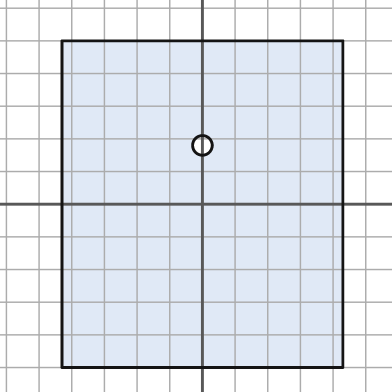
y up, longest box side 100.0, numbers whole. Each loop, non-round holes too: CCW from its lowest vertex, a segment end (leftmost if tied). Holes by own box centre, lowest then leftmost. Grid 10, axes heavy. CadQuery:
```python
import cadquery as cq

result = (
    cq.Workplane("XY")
    .moveTo(-43.0, -50.0)
    .lineTo(43.0, -50.0)
    .lineTo(43.0, 50.0)
    .lineTo(-43.0, 50.0)
    .close()
    .moveTo(0.0, 18.0)
    .circle(3.0)
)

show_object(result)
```